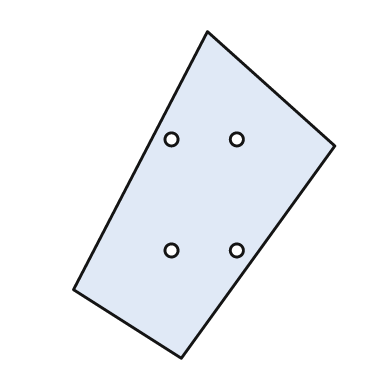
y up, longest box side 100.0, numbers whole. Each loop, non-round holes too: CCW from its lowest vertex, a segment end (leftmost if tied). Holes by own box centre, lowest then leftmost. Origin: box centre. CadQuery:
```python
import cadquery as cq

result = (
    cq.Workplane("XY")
    .moveTo(-7.0, -50.0)
    .lineTo(40.0, 15.0)
    .lineTo(1.0, 50.0)
    .lineTo(-40.0, -29.0)
    .close()
    .moveTo(-10.0, -17.0)
    .circle(2.0)
    .moveTo(10.0, -17.0)
    .circle(2.0)
    .moveTo(-10.0, 17.0)
    .circle(2.0)
    .moveTo(10.0, 17.0)
    .circle(2.0)
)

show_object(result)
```